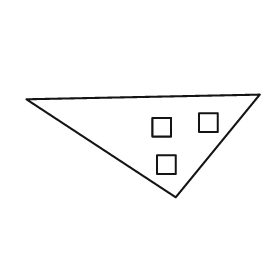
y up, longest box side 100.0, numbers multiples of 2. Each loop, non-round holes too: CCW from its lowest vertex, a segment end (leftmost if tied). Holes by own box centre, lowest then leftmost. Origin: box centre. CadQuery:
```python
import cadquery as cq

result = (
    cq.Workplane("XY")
    .moveTo(14.0, -22.0)
    .lineTo(50.0, 22.0)
    .lineTo(-50.0, 20.0)
    .close()
    .moveTo(6.0, -12.0)
    .lineTo(14.0, -12.0)
    .lineTo(14.0, -4.0)
    .lineTo(6.0, -4.0)
    .close()
    .moveTo(4.0, 4.0)
    .lineTo(12.0, 4.0)
    .lineTo(12.0, 12.0)
    .lineTo(4.0, 12.0)
    .close()
    .moveTo(24.0, 6.0)
    .lineTo(32.0, 6.0)
    .lineTo(32.0, 14.0)
    .lineTo(24.0, 14.0)
    .close()
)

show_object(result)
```